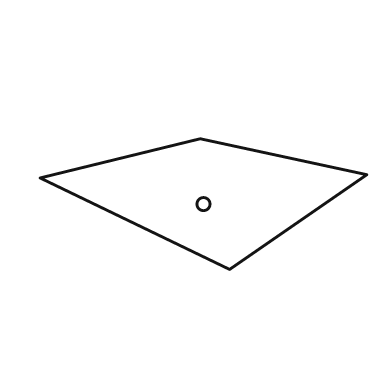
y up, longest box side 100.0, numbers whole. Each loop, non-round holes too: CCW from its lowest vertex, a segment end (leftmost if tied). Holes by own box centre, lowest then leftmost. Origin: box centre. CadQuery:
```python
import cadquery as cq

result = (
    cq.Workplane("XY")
    .moveTo(8.0, -20.0)
    .lineTo(50.0, 9.0)
    .lineTo(-1.0, 20.0)
    .lineTo(-50.0, 8.0)
    .close()
    .moveTo(0.0, 0.0)
    .circle(2.0)
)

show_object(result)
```